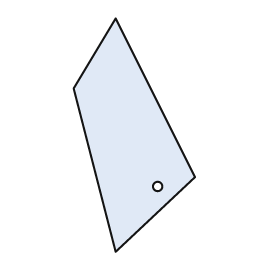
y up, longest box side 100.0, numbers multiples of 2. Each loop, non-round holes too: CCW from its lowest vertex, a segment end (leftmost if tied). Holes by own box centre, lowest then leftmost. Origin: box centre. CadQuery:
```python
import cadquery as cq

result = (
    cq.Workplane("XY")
    .moveTo(-8.0, -50.0)
    .lineTo(26.0, -18.0)
    .lineTo(-8.0, 50.0)
    .lineTo(-26.0, 20.0)
    .close()
    .moveTo(10.0, -22.0)
    .circle(2.0)
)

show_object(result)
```